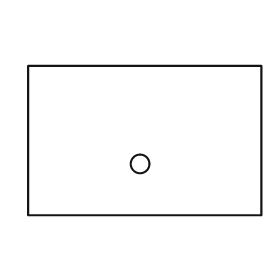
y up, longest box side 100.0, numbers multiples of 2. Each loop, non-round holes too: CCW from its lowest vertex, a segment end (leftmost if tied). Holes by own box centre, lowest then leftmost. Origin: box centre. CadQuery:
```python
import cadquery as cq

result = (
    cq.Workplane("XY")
    .moveTo(-50.0, -32.0)
    .lineTo(50.0, -32.0)
    .lineTo(50.0, 32.0)
    .lineTo(-50.0, 32.0)
    .close()
    .moveTo(-2.0, -10.0)
    .circle(4.0)
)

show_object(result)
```